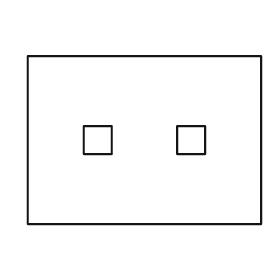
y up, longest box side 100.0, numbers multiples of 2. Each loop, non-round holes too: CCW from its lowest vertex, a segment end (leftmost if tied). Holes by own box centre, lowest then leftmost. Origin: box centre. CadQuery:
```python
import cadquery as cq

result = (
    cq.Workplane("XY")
    .moveTo(-50.0, -36.0)
    .lineTo(50.0, -36.0)
    .lineTo(50.0, 36.0)
    .lineTo(-50.0, 36.0)
    .close()
    .moveTo(-26.0, -6.0)
    .lineTo(-14.0, -6.0)
    .lineTo(-14.0, 6.0)
    .lineTo(-26.0, 6.0)
    .close()
    .moveTo(14.0, -6.0)
    .lineTo(26.0, -6.0)
    .lineTo(26.0, 6.0)
    .lineTo(14.0, 6.0)
    .close()
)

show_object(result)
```